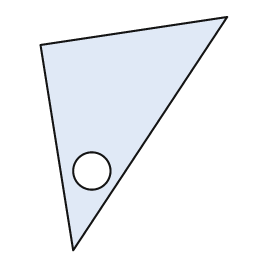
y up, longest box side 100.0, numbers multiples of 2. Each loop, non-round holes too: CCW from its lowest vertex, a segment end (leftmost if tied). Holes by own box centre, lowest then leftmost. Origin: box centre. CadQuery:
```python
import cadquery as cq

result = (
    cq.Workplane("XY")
    .moveTo(-26.0, -50.0)
    .lineTo(40.0, 50.0)
    .lineTo(-40.0, 38.0)
    .close()
    .moveTo(-18.0, -16.0)
    .circle(8.0)
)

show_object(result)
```